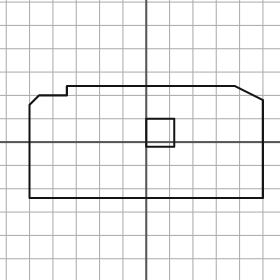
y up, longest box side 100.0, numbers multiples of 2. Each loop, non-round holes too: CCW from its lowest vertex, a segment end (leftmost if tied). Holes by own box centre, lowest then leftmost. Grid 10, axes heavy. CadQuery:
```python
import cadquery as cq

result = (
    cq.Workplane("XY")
    .moveTo(-50.0, -24.0)
    .lineTo(50.0, -24.0)
    .lineTo(50.0, 18.0)
    .lineTo(38.0, 24.0)
    .lineTo(-34.0, 24.0)
    .lineTo(-34.0, 20.0)
    .lineTo(-46.0, 20.0)
    .lineTo(-50.0, 16.0)
    .close()
    .moveTo(0.0, -2.0)
    .lineTo(12.0, -2.0)
    .lineTo(12.0, 10.0)
    .lineTo(0.0, 10.0)
    .close()
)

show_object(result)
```